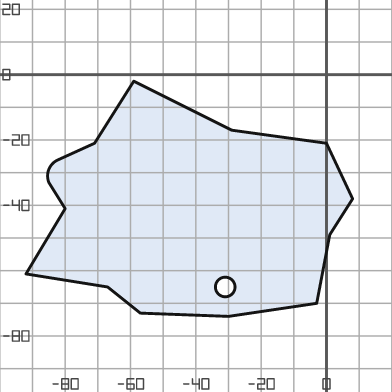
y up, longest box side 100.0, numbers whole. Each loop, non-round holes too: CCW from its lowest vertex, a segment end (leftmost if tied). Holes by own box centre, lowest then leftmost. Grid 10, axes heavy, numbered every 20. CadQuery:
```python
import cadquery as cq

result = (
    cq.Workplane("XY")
    .moveTo(-30.0, -74.0)
    .lineTo(-3.0, -70.0)
    .lineTo(1.0, -49.0)
    .lineTo(8.0, -38.0)
    .lineTo(0.0, -21.0)
    .lineTo(-29.0, -17.0)
    .lineTo(-59.0, -2.0)
    .lineTo(-71.0, -21.0)
    .lineTo(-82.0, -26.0)
    .threePointArc((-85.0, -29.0), (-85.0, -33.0))
    .lineTo(-80.0, -41.0)
    .lineTo(-92.0, -61.0)
    .lineTo(-67.0, -65.0)
    .lineTo(-57.0, -73.0)
    .close()
    .moveTo(-31.0, -65.0)
    .circle(3.0)
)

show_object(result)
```